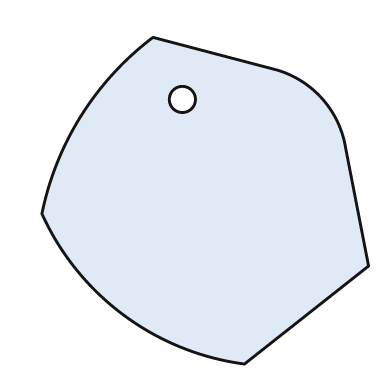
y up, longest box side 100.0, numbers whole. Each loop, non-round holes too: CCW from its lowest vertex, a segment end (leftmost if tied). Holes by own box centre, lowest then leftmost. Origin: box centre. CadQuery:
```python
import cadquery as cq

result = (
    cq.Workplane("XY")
    .moveTo(12.0, -50.0)
    .lineTo(50.0, -20.0)
    .lineTo(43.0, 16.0)
    .threePointArc((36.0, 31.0), (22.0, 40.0))
    .lineTo(-16.0, 50.0)
    .threePointArc((-38.0, 26.0), (-50.0, -4.0))
    .threePointArc((-25.0, -35.0), (12.0, -50.0))
    .close()
    .moveTo(-7.0, 31.0)
    .circle(4.0)
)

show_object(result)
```